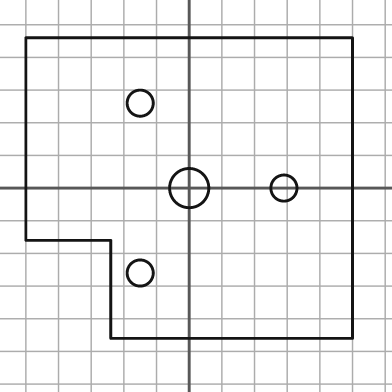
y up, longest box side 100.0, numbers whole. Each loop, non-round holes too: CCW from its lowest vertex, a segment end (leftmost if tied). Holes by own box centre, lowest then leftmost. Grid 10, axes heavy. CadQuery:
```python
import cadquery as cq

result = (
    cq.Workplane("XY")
    .moveTo(-24.0, -46.0)
    .lineTo(50.0, -46.0)
    .lineTo(50.0, 46.0)
    .lineTo(-50.0, 46.0)
    .lineTo(-50.0, -16.0)
    .lineTo(-24.0, -16.0)
    .close()
    .moveTo(-15.0, -26.0)
    .circle(4.0)
    .moveTo(0.0, 0.0)
    .circle(6.0)
    .moveTo(29.0, 0.0)
    .circle(4.0)
    .moveTo(-15.0, 26.0)
    .circle(4.0)
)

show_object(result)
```